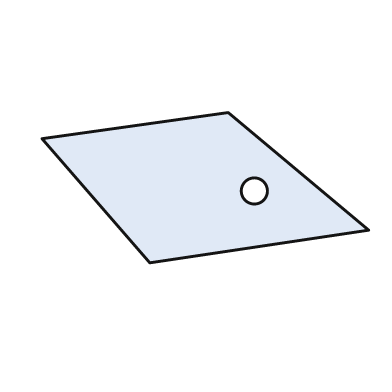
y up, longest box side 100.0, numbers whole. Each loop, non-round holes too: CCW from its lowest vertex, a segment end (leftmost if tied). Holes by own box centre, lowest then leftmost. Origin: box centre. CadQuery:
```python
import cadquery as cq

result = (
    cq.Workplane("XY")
    .moveTo(-17.0, -23.0)
    .lineTo(50.0, -13.0)
    .lineTo(7.0, 23.0)
    .lineTo(-50.0, 15.0)
    .close()
    .moveTo(15.0, -1.0)
    .circle(4.0)
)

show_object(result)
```